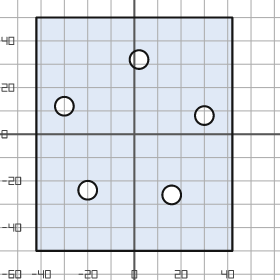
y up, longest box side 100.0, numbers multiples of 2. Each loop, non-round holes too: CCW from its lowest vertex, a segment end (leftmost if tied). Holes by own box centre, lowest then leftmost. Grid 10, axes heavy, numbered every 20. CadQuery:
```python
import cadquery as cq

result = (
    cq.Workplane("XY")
    .moveTo(-42.0, -50.0)
    .lineTo(42.0, -50.0)
    .lineTo(42.0, 50.0)
    .lineTo(-42.0, 50.0)
    .close()
    .moveTo(16.0, -26.0)
    .circle(4.0)
    .moveTo(-20.0, -24.0)
    .circle(4.0)
    .moveTo(30.0, 8.0)
    .circle(4.0)
    .moveTo(-30.0, 12.0)
    .circle(4.0)
    .moveTo(2.0, 32.0)
    .circle(4.0)
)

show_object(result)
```